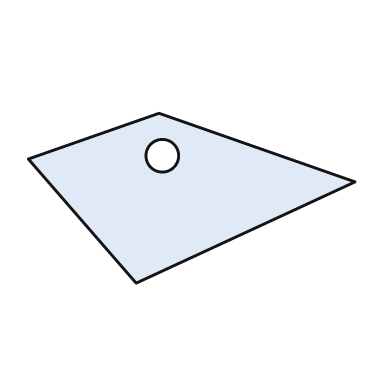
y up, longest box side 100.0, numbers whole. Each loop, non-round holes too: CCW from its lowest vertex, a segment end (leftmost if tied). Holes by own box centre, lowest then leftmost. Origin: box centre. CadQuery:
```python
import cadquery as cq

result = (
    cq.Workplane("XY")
    .moveTo(-17.0, -26.0)
    .lineTo(50.0, 5.0)
    .lineTo(-10.0, 26.0)
    .lineTo(-50.0, 12.0)
    .close()
    .moveTo(-9.0, 13.0)
    .circle(5.0)
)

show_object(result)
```